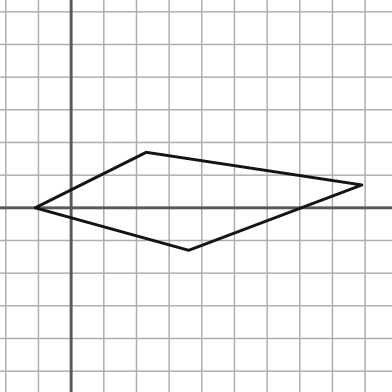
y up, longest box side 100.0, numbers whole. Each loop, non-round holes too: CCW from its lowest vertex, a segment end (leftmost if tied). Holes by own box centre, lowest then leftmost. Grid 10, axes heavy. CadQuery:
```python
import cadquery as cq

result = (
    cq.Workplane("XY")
    .moveTo(36.0, -13.0)
    .lineTo(89.0, 7.0)
    .lineTo(23.0, 17.0)
    .lineTo(-11.0, 0.0)
    .close()
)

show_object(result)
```